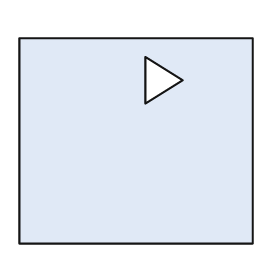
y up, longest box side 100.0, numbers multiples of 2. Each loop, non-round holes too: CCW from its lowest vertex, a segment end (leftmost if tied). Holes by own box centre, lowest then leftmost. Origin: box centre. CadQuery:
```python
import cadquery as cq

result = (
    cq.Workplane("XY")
    .moveTo(-50.0, -44.0)
    .lineTo(50.0, -44.0)
    .lineTo(50.0, 44.0)
    .lineTo(-50.0, 44.0)
    .close()
    .moveTo(4.0, 16.0)
    .lineTo(20.0, 26.0)
    .lineTo(4.0, 36.0)
    .close()
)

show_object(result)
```